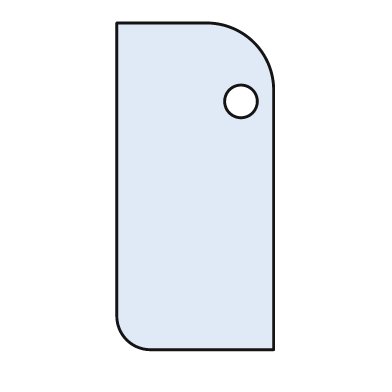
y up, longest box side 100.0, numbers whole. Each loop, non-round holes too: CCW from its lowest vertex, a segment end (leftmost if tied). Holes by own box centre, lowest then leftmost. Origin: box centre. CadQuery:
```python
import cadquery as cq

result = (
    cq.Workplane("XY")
    .moveTo(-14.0, -50.0)
    .lineTo(24.0, -50.0)
    .lineTo(24.0, 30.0)
    .threePointArc((18.0, 44.0), (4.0, 50.0))
    .lineTo(-24.0, 50.0)
    .lineTo(-24.0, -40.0)
    .threePointArc((-21.0, -47.0), (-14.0, -50.0))
    .close()
    .moveTo(14.0, 26.0)
    .circle(5.0)
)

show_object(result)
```